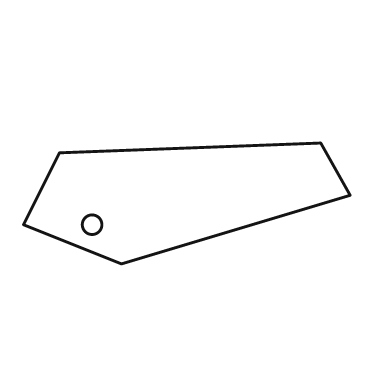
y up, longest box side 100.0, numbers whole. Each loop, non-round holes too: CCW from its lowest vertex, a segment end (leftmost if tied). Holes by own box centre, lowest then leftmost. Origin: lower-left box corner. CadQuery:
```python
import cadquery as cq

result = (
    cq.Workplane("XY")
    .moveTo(30.0, 0.0)
    .lineTo(100.0, 21.0)
    .lineTo(91.0, 37.0)
    .lineTo(11.0, 34.0)
    .lineTo(0.0, 12.0)
    .close()
    .moveTo(21.0, 12.0)
    .circle(3.0)
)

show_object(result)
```